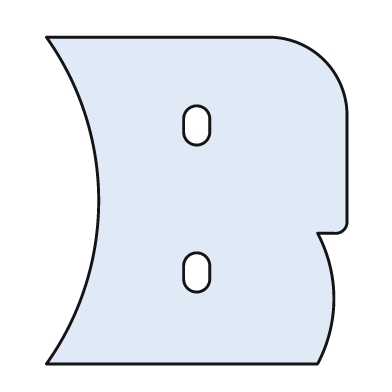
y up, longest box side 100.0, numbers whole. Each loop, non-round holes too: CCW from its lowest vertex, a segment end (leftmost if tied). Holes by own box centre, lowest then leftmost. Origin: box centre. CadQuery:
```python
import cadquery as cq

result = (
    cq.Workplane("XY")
    .moveTo(-46.0, -50.0)
    .lineTo(37.0, -50.0)
    .threePointArc((42.0, -30.0), (37.0, -10.0))
    .lineTo(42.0, -10.0)
    .threePointArc((45.0, -9.0), (46.0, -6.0))
    .lineTo(46.0, 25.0)
    .threePointArc((39.0, 43.0), (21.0, 50.0))
    .lineTo(-46.0, 50.0)
    .threePointArc((-30.0, 0.0), (-46.0, -50.0))
    .close()
    .moveTo(-4.0, -24.0)
    .threePointArc((0.0, -28.0), (4.0, -24.0))
    .lineTo(4.0, -20.0)
    .threePointArc((0.0, -16.0), (-4.0, -20.0))
    .close()
    .moveTo(-4.0, 21.0)
    .threePointArc((0.0, 17.0), (4.0, 21.0))
    .lineTo(4.0, 25.0)
    .threePointArc((0.0, 29.0), (-4.0, 25.0))
    .close()
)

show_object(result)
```